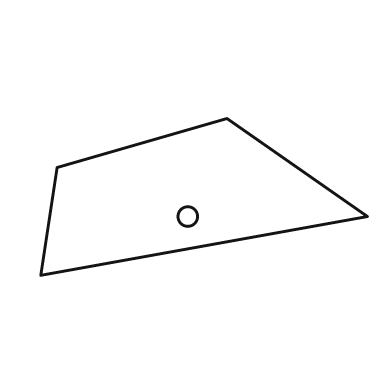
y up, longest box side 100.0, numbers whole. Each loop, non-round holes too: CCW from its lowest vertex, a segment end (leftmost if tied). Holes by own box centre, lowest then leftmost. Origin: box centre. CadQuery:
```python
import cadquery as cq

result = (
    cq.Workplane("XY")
    .moveTo(-50.0, -24.0)
    .lineTo(50.0, -6.0)
    .lineTo(7.0, 24.0)
    .lineTo(-45.0, 9.0)
    .close()
    .moveTo(-5.0, -6.0)
    .circle(3.0)
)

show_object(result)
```